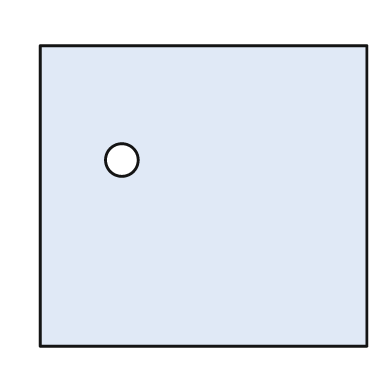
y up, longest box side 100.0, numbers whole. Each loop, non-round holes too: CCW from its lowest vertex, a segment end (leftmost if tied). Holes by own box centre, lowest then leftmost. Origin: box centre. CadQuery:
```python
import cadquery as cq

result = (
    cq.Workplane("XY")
    .moveTo(-50.0, -46.0)
    .lineTo(50.0, -46.0)
    .lineTo(50.0, 46.0)
    .lineTo(-50.0, 46.0)
    .close()
    .moveTo(-25.0, 11.0)
    .circle(5.0)
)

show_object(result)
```